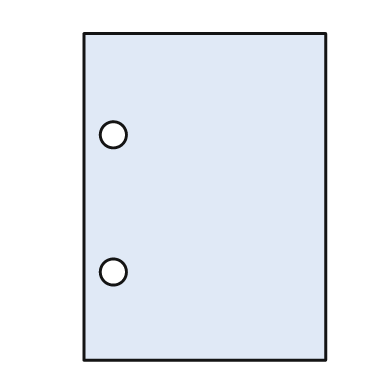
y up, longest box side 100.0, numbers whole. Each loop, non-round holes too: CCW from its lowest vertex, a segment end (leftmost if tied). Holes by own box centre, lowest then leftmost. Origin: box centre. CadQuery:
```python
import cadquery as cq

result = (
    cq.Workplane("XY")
    .moveTo(-37.0, -50.0)
    .lineTo(37.0, -50.0)
    .lineTo(37.0, 50.0)
    .lineTo(-37.0, 50.0)
    .close()
    .moveTo(-28.0, -23.0)
    .circle(4.0)
    .moveTo(-28.0, 19.0)
    .circle(4.0)
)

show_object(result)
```